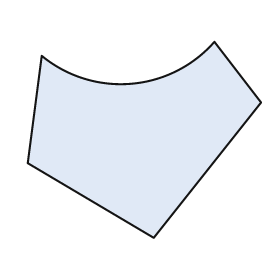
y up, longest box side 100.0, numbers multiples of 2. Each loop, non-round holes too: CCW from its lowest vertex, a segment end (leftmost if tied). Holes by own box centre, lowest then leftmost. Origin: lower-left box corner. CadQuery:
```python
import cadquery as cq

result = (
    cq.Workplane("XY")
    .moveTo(54.0, 0.0)
    .lineTo(100.0, 58.0)
    .lineTo(80.0, 84.0)
    .threePointArc((44.0, 66.0), (6.0, 78.0))
    .lineTo(0.0, 32.0)
    .close()
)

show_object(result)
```